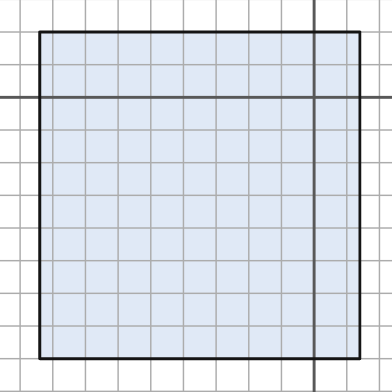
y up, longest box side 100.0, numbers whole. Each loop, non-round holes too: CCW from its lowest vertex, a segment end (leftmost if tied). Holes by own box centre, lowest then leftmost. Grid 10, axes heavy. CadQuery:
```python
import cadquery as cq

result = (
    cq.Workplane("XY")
    .moveTo(-84.0, -80.0)
    .lineTo(14.0, -80.0)
    .lineTo(14.0, 20.0)
    .lineTo(-84.0, 20.0)
    .close()
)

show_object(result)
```